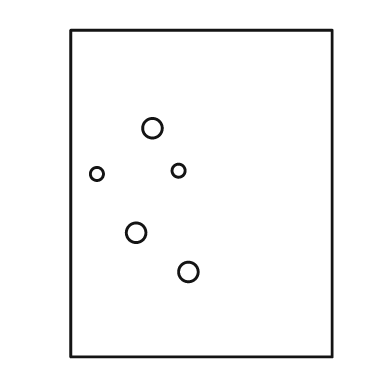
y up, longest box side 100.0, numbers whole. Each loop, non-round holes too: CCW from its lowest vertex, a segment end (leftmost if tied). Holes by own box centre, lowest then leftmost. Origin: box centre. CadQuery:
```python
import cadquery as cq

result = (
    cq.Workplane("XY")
    .moveTo(-40.0, -50.0)
    .lineTo(40.0, -50.0)
    .lineTo(40.0, 50.0)
    .lineTo(-40.0, 50.0)
    .close()
    .moveTo(-4.0, -24.0)
    .circle(3.0)
    .moveTo(-20.0, -12.0)
    .circle(3.0)
    .moveTo(-32.0, 6.0)
    .circle(2.0)
    .moveTo(-7.0, 7.0)
    .circle(2.0)
    .moveTo(-15.0, 20.0)
    .circle(3.0)
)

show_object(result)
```